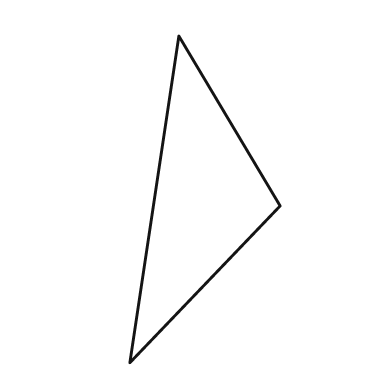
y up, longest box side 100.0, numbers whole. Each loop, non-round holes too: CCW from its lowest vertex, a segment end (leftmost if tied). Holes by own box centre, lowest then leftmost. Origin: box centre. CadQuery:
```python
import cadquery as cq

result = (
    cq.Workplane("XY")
    .moveTo(-23.0, -50.0)
    .lineTo(23.0, -2.0)
    .lineTo(-8.0, 50.0)
    .close()
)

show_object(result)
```